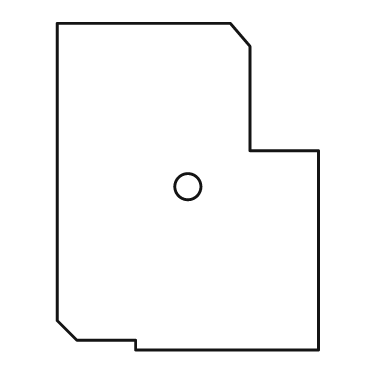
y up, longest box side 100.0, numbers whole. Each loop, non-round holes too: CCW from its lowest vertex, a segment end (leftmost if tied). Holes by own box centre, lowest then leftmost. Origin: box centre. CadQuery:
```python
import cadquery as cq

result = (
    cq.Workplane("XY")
    .moveTo(-16.0, -50.0)
    .lineTo(40.0, -50.0)
    .lineTo(40.0, 11.0)
    .lineTo(19.0, 11.0)
    .lineTo(19.0, 43.0)
    .lineTo(13.0, 50.0)
    .lineTo(-40.0, 50.0)
    .lineTo(-40.0, -41.0)
    .lineTo(-34.0, -47.0)
    .lineTo(-16.0, -47.0)
    .close()
    .moveTo(0.0, 0.0)
    .circle(4.0)
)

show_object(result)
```